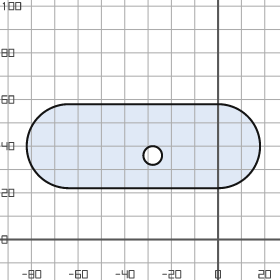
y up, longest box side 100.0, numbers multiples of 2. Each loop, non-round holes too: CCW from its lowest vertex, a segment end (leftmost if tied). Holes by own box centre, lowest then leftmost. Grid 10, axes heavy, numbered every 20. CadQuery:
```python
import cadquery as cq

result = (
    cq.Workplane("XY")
    .moveTo(-64.0, 22.0)
    .lineTo(0.0, 22.0)
    .threePointArc((18.0, 40.0), (0.0, 58.0))
    .lineTo(-64.0, 58.0)
    .threePointArc((-82.0, 40.0), (-64.0, 22.0))
    .close()
    .moveTo(-28.0, 36.0)
    .circle(4.0)
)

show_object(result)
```